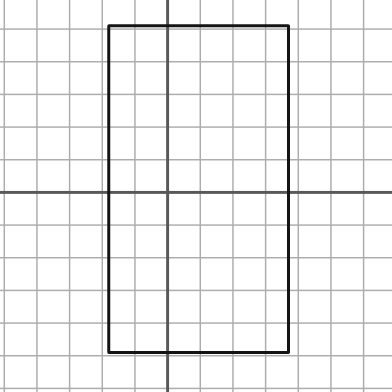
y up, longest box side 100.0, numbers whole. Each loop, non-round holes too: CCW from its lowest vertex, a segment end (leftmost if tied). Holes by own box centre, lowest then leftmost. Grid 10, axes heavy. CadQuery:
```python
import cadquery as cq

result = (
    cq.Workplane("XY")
    .moveTo(-18.0, -49.0)
    .lineTo(37.0, -49.0)
    .lineTo(37.0, 51.0)
    .lineTo(-18.0, 51.0)
    .close()
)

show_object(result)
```